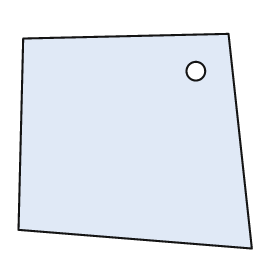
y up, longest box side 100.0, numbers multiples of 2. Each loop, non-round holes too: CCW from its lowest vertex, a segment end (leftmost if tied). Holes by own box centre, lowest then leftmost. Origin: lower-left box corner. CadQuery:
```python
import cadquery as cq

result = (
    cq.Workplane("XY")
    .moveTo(100.0, 0.0)
    .lineTo(90.0, 92.0)
    .lineTo(2.0, 90.0)
    .lineTo(0.0, 8.0)
    .close()
    .moveTo(76.0, 76.0)
    .circle(4.0)
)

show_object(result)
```